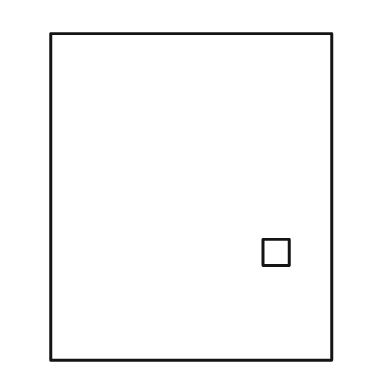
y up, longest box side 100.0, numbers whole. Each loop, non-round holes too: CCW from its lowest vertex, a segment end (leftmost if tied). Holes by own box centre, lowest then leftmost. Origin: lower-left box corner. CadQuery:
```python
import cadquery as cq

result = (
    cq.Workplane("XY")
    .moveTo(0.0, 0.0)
    .lineTo(86.0, 0.0)
    .lineTo(86.0, 100.0)
    .lineTo(0.0, 100.0)
    .close()
    .moveTo(65.0, 29.0)
    .lineTo(73.0, 29.0)
    .lineTo(73.0, 37.0)
    .lineTo(65.0, 37.0)
    .close()
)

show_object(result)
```